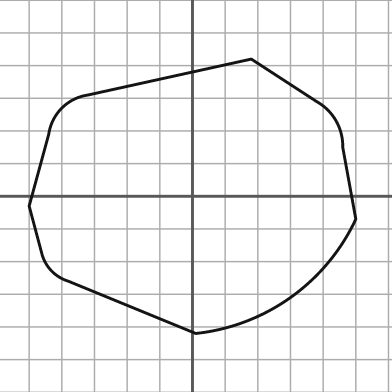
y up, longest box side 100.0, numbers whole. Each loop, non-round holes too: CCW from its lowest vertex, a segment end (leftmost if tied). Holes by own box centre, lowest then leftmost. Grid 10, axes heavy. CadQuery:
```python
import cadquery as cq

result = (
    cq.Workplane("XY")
    .moveTo(1.0, -42.0)
    .threePointArc((30.0, -31.0), (50.0, -7.0))
    .lineTo(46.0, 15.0)
    .threePointArc((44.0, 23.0), (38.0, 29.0))
    .lineTo(18.0, 42.0)
    .lineTo(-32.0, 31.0)
    .threePointArc((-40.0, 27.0), (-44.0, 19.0))
    .lineTo(-50.0, -3.0)
    .lineTo(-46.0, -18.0)
    .threePointArc((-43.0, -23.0), (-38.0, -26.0))
    .close()
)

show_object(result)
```